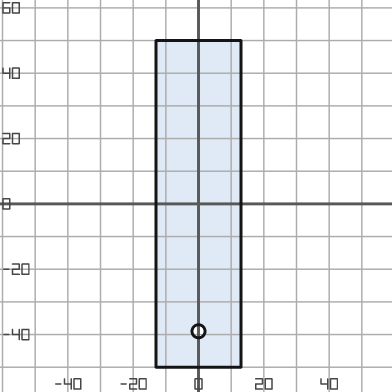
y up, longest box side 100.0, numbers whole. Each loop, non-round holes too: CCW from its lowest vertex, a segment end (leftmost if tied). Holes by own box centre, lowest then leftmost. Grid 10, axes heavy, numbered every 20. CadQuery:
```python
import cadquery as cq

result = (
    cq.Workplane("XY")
    .moveTo(-13.0, -50.0)
    .lineTo(13.0, -50.0)
    .lineTo(13.0, 50.0)
    .lineTo(-13.0, 50.0)
    .close()
    .moveTo(0.0, -39.0)
    .circle(2.0)
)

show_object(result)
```